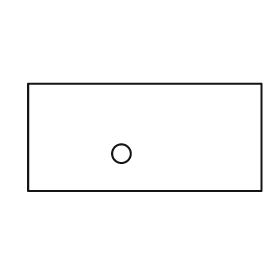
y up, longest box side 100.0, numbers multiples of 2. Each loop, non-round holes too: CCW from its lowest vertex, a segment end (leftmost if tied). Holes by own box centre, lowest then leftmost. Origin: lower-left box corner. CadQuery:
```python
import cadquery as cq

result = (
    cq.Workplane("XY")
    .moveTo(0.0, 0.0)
    .lineTo(100.0, 0.0)
    .lineTo(100.0, 46.0)
    .lineTo(0.0, 46.0)
    .close()
    .moveTo(40.0, 16.0)
    .circle(4.0)
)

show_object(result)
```